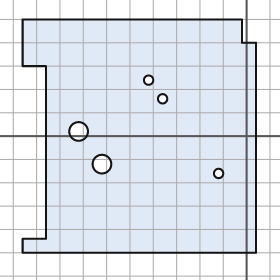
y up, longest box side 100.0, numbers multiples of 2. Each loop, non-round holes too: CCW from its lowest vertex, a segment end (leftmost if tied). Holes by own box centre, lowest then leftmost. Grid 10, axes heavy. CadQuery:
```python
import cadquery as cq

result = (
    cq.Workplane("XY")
    .moveTo(-96.0, -50.0)
    .lineTo(4.0, -50.0)
    .lineTo(4.0, 40.0)
    .lineTo(-2.0, 40.0)
    .lineTo(-2.0, 50.0)
    .lineTo(-96.0, 50.0)
    .lineTo(-96.0, 30.0)
    .lineTo(-86.0, 30.0)
    .lineTo(-86.0, -44.0)
    .lineTo(-96.0, -44.0)
    .close()
    .moveTo(-12.0, -16.0)
    .circle(2.0)
    .moveTo(-62.0, -12.0)
    .circle(4.0)
    .moveTo(-72.0, 2.0)
    .circle(4.0)
    .moveTo(-36.0, 16.0)
    .circle(2.0)
    .moveTo(-42.0, 24.0)
    .circle(2.0)
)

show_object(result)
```